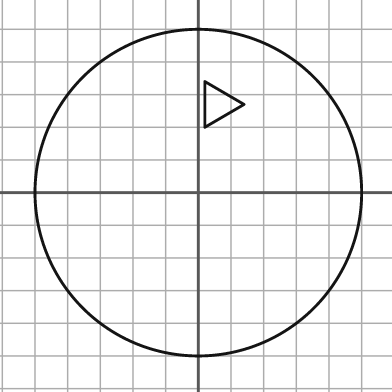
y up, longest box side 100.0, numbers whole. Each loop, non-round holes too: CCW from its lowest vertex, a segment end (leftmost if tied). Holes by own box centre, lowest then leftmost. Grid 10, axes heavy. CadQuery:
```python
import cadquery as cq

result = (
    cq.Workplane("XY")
    .moveTo(0.0, 0.0)
    .circle(50.0)
    .moveTo(2.0, 20.0)
    .lineTo(14.0, 27.0)
    .lineTo(2.0, 34.0)
    .close()
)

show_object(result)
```